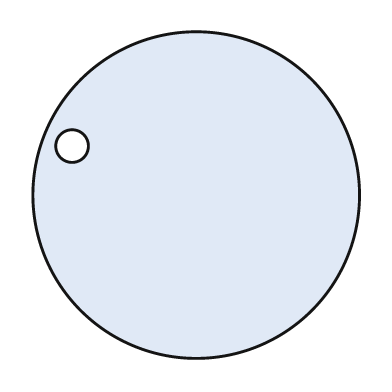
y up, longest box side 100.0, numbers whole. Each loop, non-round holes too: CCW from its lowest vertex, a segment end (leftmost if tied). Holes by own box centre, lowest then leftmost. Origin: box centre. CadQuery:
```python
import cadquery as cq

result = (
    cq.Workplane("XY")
    .moveTo(0.0, 0.0)
    .circle(50.0)
    .moveTo(-38.0, 15.0)
    .circle(5.0)
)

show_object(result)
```